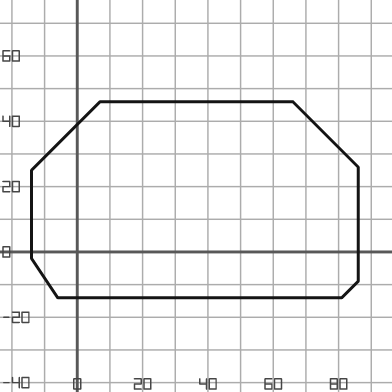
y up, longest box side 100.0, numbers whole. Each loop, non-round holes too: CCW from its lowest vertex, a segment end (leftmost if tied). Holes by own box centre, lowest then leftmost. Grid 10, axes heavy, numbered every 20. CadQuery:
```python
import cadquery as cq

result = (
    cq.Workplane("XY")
    .moveTo(-6.0, -14.0)
    .lineTo(81.0, -14.0)
    .lineTo(86.0, -9.0)
    .lineTo(86.0, 26.0)
    .lineTo(66.0, 46.0)
    .lineTo(7.0, 46.0)
    .lineTo(-14.0, 25.0)
    .lineTo(-14.0, -2.0)
    .close()
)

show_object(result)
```